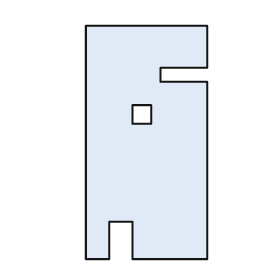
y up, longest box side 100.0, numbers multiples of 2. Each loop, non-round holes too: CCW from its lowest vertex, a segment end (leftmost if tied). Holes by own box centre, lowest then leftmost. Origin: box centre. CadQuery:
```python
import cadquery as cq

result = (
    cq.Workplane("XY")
    .moveTo(-26.0, -50.0)
    .lineTo(-16.0, -50.0)
    .lineTo(-16.0, -34.0)
    .lineTo(-6.0, -34.0)
    .lineTo(-6.0, -50.0)
    .lineTo(26.0, -50.0)
    .lineTo(26.0, 26.0)
    .lineTo(6.0, 26.0)
    .lineTo(6.0, 32.0)
    .lineTo(26.0, 32.0)
    .lineTo(26.0, 50.0)
    .lineTo(-26.0, 50.0)
    .close()
    .moveTo(-6.0, 8.0)
    .lineTo(2.0, 8.0)
    .lineTo(2.0, 16.0)
    .lineTo(-6.0, 16.0)
    .close()
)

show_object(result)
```